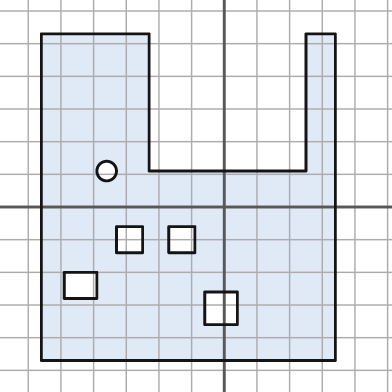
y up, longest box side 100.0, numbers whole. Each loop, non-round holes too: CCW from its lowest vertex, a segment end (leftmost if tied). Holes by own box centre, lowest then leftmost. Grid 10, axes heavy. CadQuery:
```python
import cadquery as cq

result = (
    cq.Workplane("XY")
    .moveTo(-56.0, -47.0)
    .lineTo(34.0, -47.0)
    .lineTo(34.0, 53.0)
    .lineTo(25.0, 53.0)
    .lineTo(25.0, 11.0)
    .lineTo(-23.0, 11.0)
    .lineTo(-23.0, 53.0)
    .lineTo(-56.0, 53.0)
    .close()
    .moveTo(-6.0, -36.0)
    .lineTo(4.0, -36.0)
    .lineTo(4.0, -26.0)
    .lineTo(-6.0, -26.0)
    .close()
    .moveTo(-49.0, -28.0)
    .lineTo(-39.0, -28.0)
    .lineTo(-39.0, -20.0)
    .lineTo(-49.0, -20.0)
    .close()
    .moveTo(-33.0, -14.0)
    .lineTo(-25.0, -14.0)
    .lineTo(-25.0, -6.0)
    .lineTo(-33.0, -6.0)
    .close()
    .moveTo(-17.0, -14.0)
    .lineTo(-9.0, -14.0)
    .lineTo(-9.0, -6.0)
    .lineTo(-17.0, -6.0)
    .close()
    .moveTo(-36.0, 11.0)
    .circle(3.0)
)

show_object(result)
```